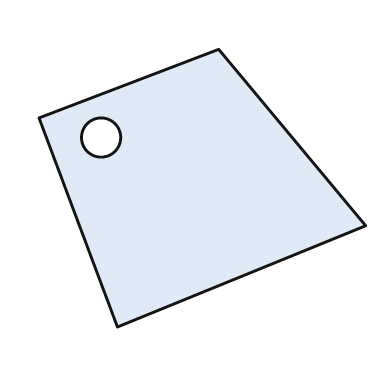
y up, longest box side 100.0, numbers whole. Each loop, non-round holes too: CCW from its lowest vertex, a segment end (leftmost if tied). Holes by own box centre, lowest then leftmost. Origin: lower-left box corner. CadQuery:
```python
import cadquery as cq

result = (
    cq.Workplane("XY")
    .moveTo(24.0, 0.0)
    .lineTo(100.0, 31.0)
    .lineTo(55.0, 85.0)
    .lineTo(0.0, 64.0)
    .close()
    .moveTo(19.0, 58.0)
    .circle(6.0)
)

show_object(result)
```